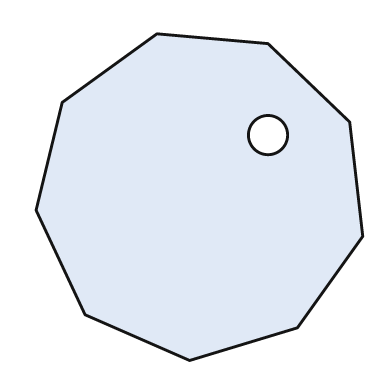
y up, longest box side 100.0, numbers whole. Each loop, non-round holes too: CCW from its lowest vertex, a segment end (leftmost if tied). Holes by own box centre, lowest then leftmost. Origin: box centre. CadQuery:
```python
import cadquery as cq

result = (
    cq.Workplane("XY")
    .moveTo(-3.0, -50.0)
    .lineTo(30.0, -40.0)
    .lineTo(50.0, -12.0)
    .lineTo(46.0, 23.0)
    .lineTo(21.0, 47.0)
    .lineTo(-13.0, 50.0)
    .lineTo(-42.0, 29.0)
    .lineTo(-50.0, -4.0)
    .lineTo(-35.0, -36.0)
    .close()
    .moveTo(21.0, 19.0)
    .circle(6.0)
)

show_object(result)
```